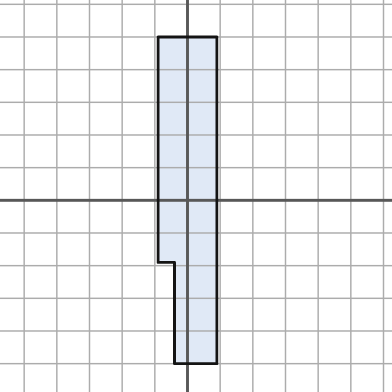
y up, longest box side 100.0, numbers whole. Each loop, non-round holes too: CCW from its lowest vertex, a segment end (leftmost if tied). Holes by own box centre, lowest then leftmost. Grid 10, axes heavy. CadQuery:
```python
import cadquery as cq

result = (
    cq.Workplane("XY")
    .moveTo(-4.0, -50.0)
    .lineTo(9.0, -50.0)
    .lineTo(9.0, 50.0)
    .lineTo(-9.0, 50.0)
    .lineTo(-9.0, -19.0)
    .lineTo(-4.0, -19.0)
    .close()
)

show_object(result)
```